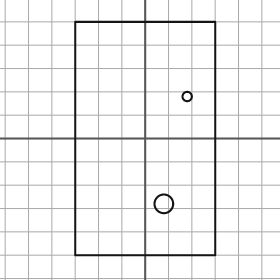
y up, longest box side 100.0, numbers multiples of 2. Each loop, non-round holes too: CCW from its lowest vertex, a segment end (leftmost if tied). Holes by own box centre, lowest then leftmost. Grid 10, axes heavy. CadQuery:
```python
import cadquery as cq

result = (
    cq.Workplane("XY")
    .moveTo(-30.0, -50.0)
    .lineTo(30.0, -50.0)
    .lineTo(30.0, 50.0)
    .lineTo(-30.0, 50.0)
    .close()
    .moveTo(8.0, -28.0)
    .circle(4.0)
    .moveTo(18.0, 18.0)
    .circle(2.0)
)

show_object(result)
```